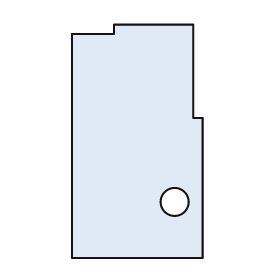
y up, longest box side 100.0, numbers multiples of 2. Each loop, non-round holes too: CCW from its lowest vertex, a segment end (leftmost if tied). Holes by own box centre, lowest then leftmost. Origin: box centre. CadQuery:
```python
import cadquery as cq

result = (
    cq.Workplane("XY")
    .moveTo(-28.0, -50.0)
    .lineTo(28.0, -50.0)
    .lineTo(28.0, 10.0)
    .lineTo(24.0, 10.0)
    .lineTo(24.0, 50.0)
    .lineTo(-10.0, 50.0)
    .lineTo(-10.0, 46.0)
    .lineTo(-28.0, 46.0)
    .close()
    .moveTo(16.0, -26.0)
    .circle(6.0)
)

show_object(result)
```